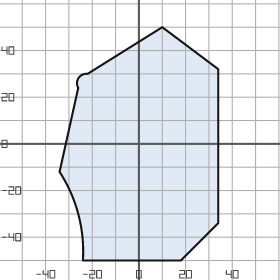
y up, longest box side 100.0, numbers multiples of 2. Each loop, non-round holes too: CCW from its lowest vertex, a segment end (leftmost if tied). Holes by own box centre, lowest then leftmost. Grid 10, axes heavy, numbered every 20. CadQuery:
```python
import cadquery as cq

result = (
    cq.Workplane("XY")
    .moveTo(-24.0, -50.0)
    .lineTo(18.0, -50.0)
    .lineTo(34.0, -34.0)
    .lineTo(34.0, 32.0)
    .lineTo(10.0, 50.0)
    .lineTo(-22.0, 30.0)
    .threePointArc((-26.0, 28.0), (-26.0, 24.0))
    .lineTo(-34.0, -12.0)
    .threePointArc((-26.0, -30.0), (-24.0, -50.0))
    .close()
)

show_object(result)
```